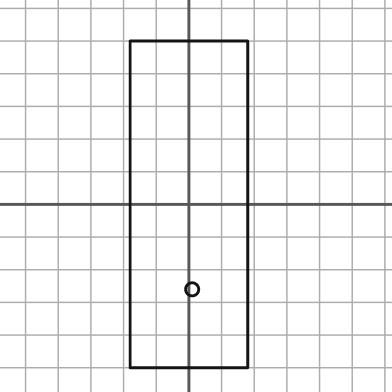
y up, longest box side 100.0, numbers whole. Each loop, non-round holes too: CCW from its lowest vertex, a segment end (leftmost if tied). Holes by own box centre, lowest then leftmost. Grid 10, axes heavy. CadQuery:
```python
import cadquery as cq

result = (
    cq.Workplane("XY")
    .moveTo(-18.0, -50.0)
    .lineTo(18.0, -50.0)
    .lineTo(18.0, 50.0)
    .lineTo(-18.0, 50.0)
    .close()
    .moveTo(1.0, -26.0)
    .circle(2.0)
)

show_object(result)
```